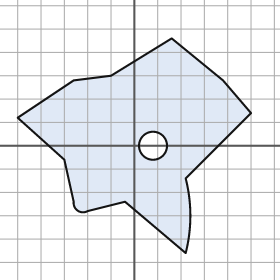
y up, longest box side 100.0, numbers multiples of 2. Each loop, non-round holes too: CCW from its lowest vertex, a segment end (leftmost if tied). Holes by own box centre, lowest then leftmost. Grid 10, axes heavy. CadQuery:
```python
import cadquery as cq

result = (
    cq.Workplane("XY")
    .moveTo(22.0, -46.0)
    .threePointArc((24.0, -30.0), (22.0, -14.0))
    .lineTo(50.0, 14.0)
    .lineTo(38.0, 28.0)
    .lineTo(16.0, 46.0)
    .lineTo(-10.0, 30.0)
    .lineTo(-26.0, 28.0)
    .lineTo(-50.0, 12.0)
    .lineTo(-30.0, -6.0)
    .lineTo(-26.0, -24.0)
    .threePointArc((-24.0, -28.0), (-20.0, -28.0))
    .lineTo(-4.0, -24.0)
    .close()
    .moveTo(8.0, 0.0)
    .circle(6.0)
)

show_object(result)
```